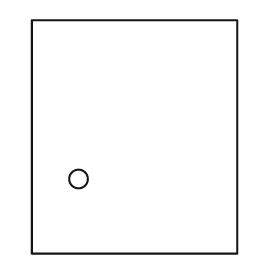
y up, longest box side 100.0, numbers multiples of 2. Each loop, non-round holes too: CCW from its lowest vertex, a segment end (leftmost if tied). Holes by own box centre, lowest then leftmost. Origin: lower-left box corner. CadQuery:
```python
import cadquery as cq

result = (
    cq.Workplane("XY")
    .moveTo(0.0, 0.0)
    .lineTo(88.0, 0.0)
    .lineTo(88.0, 100.0)
    .lineTo(0.0, 100.0)
    .close()
    .moveTo(20.0, 32.0)
    .circle(4.0)
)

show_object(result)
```